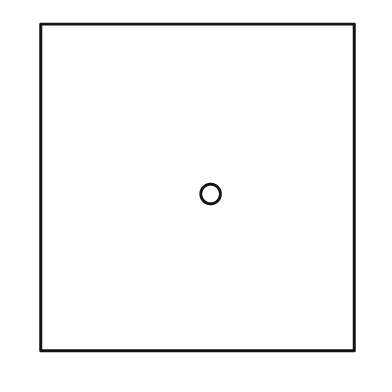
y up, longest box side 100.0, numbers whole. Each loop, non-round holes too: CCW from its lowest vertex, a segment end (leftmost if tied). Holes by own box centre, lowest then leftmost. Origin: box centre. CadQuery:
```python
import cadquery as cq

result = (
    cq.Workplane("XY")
    .moveTo(-48.0, -50.0)
    .lineTo(48.0, -50.0)
    .lineTo(48.0, 50.0)
    .lineTo(-48.0, 50.0)
    .close()
    .moveTo(4.0, -2.0)
    .circle(3.0)
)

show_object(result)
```